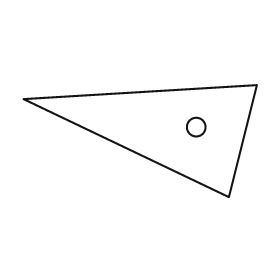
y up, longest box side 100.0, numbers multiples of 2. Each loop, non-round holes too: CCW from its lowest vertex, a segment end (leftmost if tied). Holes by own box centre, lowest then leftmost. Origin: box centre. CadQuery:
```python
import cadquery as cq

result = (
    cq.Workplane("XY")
    .moveTo(38.0, -24.0)
    .lineTo(50.0, 24.0)
    .lineTo(-50.0, 18.0)
    .close()
    .moveTo(24.0, 6.0)
    .circle(4.0)
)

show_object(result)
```